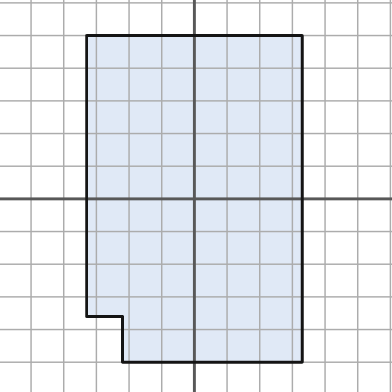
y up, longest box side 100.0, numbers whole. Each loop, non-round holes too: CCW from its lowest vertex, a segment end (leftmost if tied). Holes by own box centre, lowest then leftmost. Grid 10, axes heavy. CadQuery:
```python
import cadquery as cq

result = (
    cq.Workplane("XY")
    .moveTo(-22.0, -50.0)
    .lineTo(33.0, -50.0)
    .lineTo(33.0, 50.0)
    .lineTo(-33.0, 50.0)
    .lineTo(-33.0, -36.0)
    .lineTo(-22.0, -36.0)
    .close()
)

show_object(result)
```